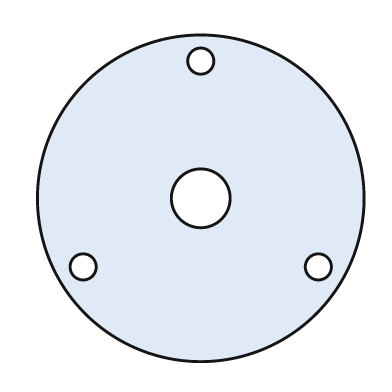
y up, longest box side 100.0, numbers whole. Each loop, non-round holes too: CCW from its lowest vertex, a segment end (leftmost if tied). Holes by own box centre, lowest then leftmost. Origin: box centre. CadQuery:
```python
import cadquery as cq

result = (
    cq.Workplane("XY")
    .moveTo(0.0, 0.0)
    .circle(50.0)
    .moveTo(-36.0, -21.0)
    .circle(4.0)
    .moveTo(36.0, -21.0)
    .circle(4.0)
    .moveTo(0.0, 0.0)
    .circle(9.0)
    .moveTo(0.0, 42.0)
    .circle(4.0)
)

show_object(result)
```